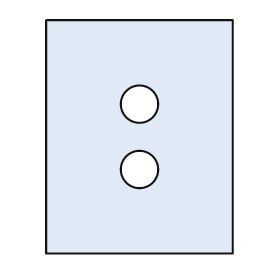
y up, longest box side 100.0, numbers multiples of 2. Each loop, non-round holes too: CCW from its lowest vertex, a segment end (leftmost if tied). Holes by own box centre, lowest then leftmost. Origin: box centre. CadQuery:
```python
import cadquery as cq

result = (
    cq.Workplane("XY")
    .moveTo(-40.0, -50.0)
    .lineTo(40.0, -50.0)
    .lineTo(40.0, 50.0)
    .lineTo(-40.0, 50.0)
    .close()
    .moveTo(0.0, -14.0)
    .circle(8.0)
    .moveTo(0.0, 14.0)
    .circle(8.0)
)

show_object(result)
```